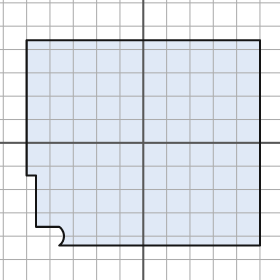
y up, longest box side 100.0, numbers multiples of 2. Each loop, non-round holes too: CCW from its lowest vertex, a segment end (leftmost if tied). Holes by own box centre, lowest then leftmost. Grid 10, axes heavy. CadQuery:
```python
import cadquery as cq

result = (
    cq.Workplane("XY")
    .moveTo(-36.0, -44.0)
    .lineTo(50.0, -44.0)
    .lineTo(50.0, 44.0)
    .lineTo(-50.0, 44.0)
    .lineTo(-50.0, -14.0)
    .lineTo(-46.0, -14.0)
    .lineTo(-46.0, -36.0)
    .lineTo(-36.0, -36.0)
    .threePointArc((-34.0, -40.0), (-36.0, -44.0))
    .close()
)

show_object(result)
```